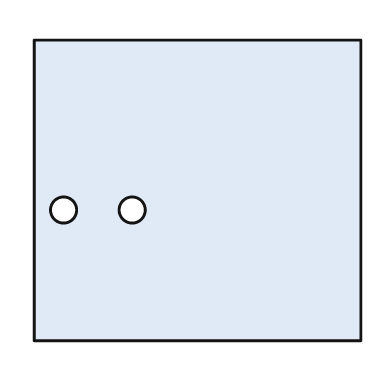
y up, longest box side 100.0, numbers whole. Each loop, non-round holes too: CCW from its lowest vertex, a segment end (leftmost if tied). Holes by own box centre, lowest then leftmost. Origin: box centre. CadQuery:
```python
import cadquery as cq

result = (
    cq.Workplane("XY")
    .moveTo(-50.0, -46.0)
    .lineTo(50.0, -46.0)
    .lineTo(50.0, 46.0)
    .lineTo(-50.0, 46.0)
    .close()
    .moveTo(-41.0, -6.0)
    .circle(4.0)
    .moveTo(-20.0, -6.0)
    .circle(4.0)
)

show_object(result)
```